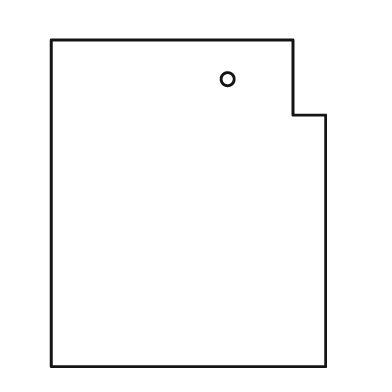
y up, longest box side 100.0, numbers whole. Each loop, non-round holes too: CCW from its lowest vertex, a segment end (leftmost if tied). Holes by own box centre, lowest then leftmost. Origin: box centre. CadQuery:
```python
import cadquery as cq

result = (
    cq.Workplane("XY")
    .moveTo(-42.0, -50.0)
    .lineTo(42.0, -50.0)
    .lineTo(42.0, 27.0)
    .lineTo(32.0, 27.0)
    .lineTo(32.0, 50.0)
    .lineTo(-42.0, 50.0)
    .close()
    .moveTo(12.0, 38.0)
    .circle(2.0)
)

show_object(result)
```